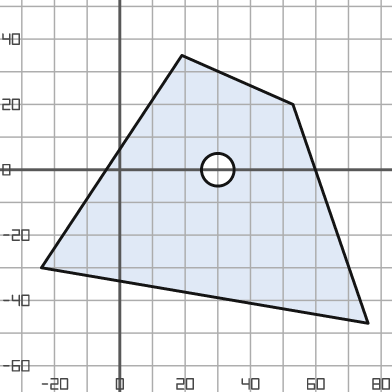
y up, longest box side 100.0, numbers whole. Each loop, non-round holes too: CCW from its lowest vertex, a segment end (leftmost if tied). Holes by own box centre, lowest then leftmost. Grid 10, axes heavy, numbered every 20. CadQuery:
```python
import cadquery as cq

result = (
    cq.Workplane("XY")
    .moveTo(76.0, -47.0)
    .lineTo(53.0, 20.0)
    .lineTo(19.0, 35.0)
    .lineTo(-24.0, -30.0)
    .close()
    .moveTo(30.0, 0.0)
    .circle(5.0)
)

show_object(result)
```